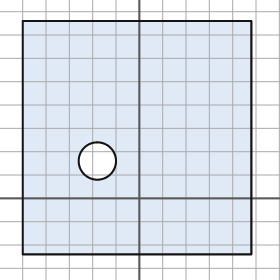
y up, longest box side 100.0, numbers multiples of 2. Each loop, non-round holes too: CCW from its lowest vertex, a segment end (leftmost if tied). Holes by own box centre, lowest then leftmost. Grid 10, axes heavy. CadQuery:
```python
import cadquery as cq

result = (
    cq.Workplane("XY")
    .moveTo(-50.0, -24.0)
    .lineTo(48.0, -24.0)
    .lineTo(48.0, 76.0)
    .lineTo(-50.0, 76.0)
    .close()
    .moveTo(-18.0, 16.0)
    .circle(8.0)
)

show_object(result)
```